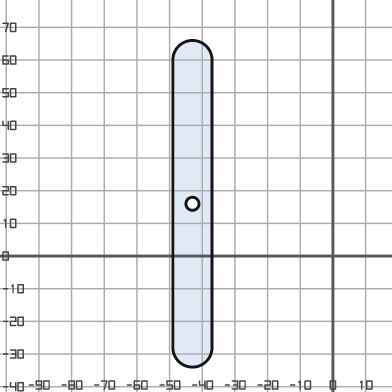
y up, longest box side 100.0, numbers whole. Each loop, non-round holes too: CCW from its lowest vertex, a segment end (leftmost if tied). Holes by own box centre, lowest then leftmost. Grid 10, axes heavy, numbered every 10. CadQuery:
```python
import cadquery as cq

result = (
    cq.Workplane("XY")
    .moveTo(-49.0, -28.0)
    .threePointArc((-43.0, -34.0), (-37.0, -28.0))
    .lineTo(-37.0, 60.0)
    .threePointArc((-43.0, 66.0), (-49.0, 60.0))
    .close()
    .moveTo(-43.0, 16.0)
    .circle(2.0)
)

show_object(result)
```